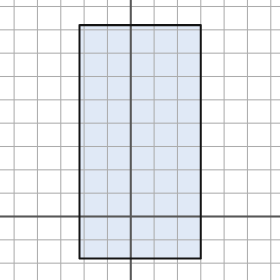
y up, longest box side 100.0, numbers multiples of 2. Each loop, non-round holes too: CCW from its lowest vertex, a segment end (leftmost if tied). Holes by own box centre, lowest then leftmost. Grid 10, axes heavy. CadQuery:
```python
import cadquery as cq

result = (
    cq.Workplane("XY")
    .moveTo(-22.0, -18.0)
    .lineTo(30.0, -18.0)
    .lineTo(30.0, 82.0)
    .lineTo(-22.0, 82.0)
    .close()
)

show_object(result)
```